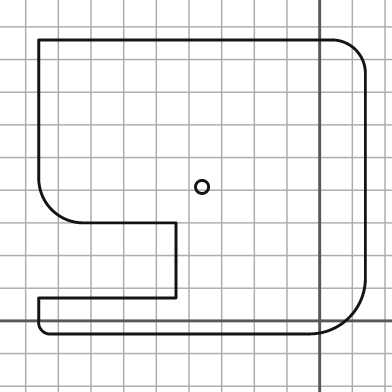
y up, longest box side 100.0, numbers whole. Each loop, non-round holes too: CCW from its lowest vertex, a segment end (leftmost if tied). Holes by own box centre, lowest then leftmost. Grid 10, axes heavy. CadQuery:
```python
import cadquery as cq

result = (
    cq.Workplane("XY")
    .moveTo(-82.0, -4.0)
    .lineTo(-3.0, -4.0)
    .threePointArc((9.0, 1.0), (14.0, 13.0))
    .lineTo(14.0, 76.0)
    .threePointArc((11.0, 83.0), (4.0, 86.0))
    .lineTo(-86.0, 86.0)
    .lineTo(-86.0, 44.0)
    .threePointArc((-82.0, 34.0), (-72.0, 30.0))
    .lineTo(-44.0, 30.0)
    .lineTo(-44.0, 7.0)
    .lineTo(-86.0, 7.0)
    .lineTo(-86.0, 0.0)
    .threePointArc((-85.0, -3.0), (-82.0, -4.0))
    .close()
    .moveTo(-36.0, 41.0)
    .circle(2.0)
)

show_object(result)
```